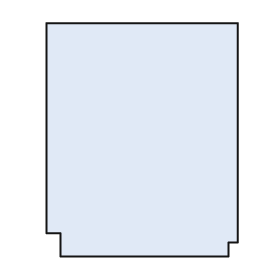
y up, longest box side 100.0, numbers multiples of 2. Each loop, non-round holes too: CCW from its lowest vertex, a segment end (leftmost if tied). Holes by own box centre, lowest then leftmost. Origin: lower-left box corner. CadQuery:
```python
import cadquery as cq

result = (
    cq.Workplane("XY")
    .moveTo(6.0, 0.0)
    .lineTo(78.0, 0.0)
    .lineTo(78.0, 6.0)
    .lineTo(82.0, 6.0)
    .lineTo(82.0, 100.0)
    .lineTo(0.0, 100.0)
    .lineTo(0.0, 10.0)
    .lineTo(6.0, 10.0)
    .close()
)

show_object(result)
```